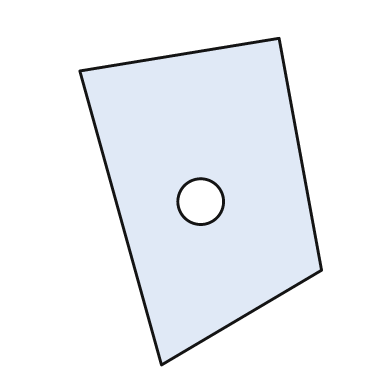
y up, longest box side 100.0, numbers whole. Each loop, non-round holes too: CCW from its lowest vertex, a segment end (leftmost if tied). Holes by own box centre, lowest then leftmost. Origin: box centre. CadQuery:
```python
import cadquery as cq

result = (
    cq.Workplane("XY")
    .moveTo(-12.0, -50.0)
    .lineTo(37.0, -21.0)
    .lineTo(24.0, 50.0)
    .lineTo(-37.0, 40.0)
    .close()
    .moveTo(0.0, 0.0)
    .circle(7.0)
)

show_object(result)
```